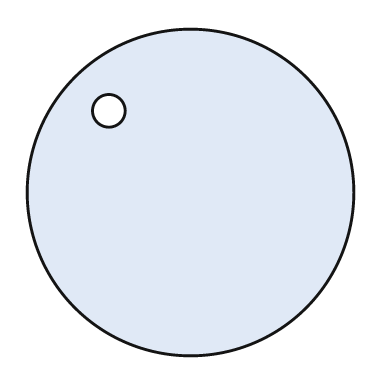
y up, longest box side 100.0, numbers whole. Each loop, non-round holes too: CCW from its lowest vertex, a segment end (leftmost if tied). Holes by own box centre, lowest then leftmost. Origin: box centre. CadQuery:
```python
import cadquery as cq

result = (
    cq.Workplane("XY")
    .moveTo(0.0, 0.0)
    .circle(50.0)
    .moveTo(-25.0, 25.0)
    .circle(5.0)
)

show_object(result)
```